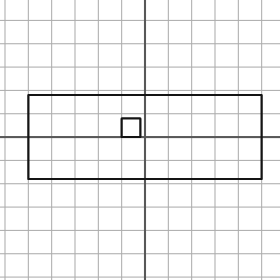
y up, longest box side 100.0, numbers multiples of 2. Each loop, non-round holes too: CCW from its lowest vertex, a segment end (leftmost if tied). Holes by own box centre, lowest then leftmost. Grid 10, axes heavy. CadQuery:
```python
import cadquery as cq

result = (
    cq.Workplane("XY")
    .moveTo(-50.0, -18.0)
    .lineTo(50.0, -18.0)
    .lineTo(50.0, 18.0)
    .lineTo(-50.0, 18.0)
    .close()
    .moveTo(-10.0, 0.0)
    .lineTo(-2.0, 0.0)
    .lineTo(-2.0, 8.0)
    .lineTo(-10.0, 8.0)
    .close()
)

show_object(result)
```